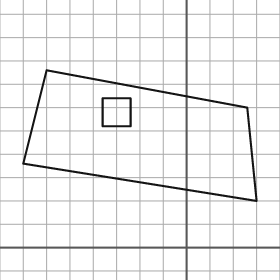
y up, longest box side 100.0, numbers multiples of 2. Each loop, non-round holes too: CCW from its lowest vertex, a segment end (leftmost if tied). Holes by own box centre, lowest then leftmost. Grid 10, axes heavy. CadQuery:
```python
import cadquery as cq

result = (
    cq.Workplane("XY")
    .moveTo(30.0, 20.0)
    .lineTo(26.0, 60.0)
    .lineTo(-60.0, 76.0)
    .lineTo(-70.0, 36.0)
    .close()
    .moveTo(-36.0, 52.0)
    .lineTo(-24.0, 52.0)
    .lineTo(-24.0, 64.0)
    .lineTo(-36.0, 64.0)
    .close()
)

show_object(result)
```